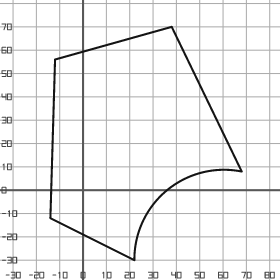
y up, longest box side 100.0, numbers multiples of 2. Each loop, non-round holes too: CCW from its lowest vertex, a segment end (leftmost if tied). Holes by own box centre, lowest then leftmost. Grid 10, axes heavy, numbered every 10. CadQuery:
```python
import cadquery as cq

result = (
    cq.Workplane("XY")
    .moveTo(22.0, -30.0)
    .threePointArc((36.0, 0.0), (68.0, 8.0))
    .lineTo(38.0, 70.0)
    .lineTo(-12.0, 56.0)
    .lineTo(-14.0, -12.0)
    .close()
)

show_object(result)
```